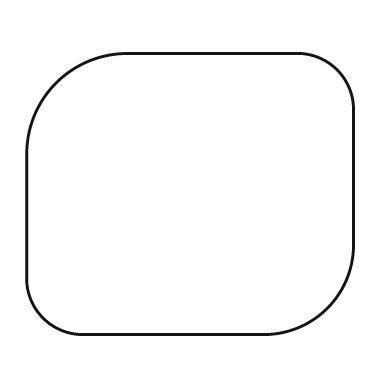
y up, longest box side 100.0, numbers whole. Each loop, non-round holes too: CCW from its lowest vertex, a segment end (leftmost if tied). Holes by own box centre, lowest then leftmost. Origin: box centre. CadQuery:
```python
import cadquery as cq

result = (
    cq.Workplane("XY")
    .moveTo(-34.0, -43.0)
    .lineTo(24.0, -43.0)
    .threePointArc((42.0, -35.0), (50.0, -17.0))
    .lineTo(50.0, 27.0)
    .threePointArc((45.0, 38.0), (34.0, 43.0))
    .lineTo(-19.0, 43.0)
    .threePointArc((-41.0, 34.0), (-50.0, 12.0))
    .lineTo(-50.0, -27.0)
    .threePointArc((-45.0, -38.0), (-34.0, -43.0))
    .close()
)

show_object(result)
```